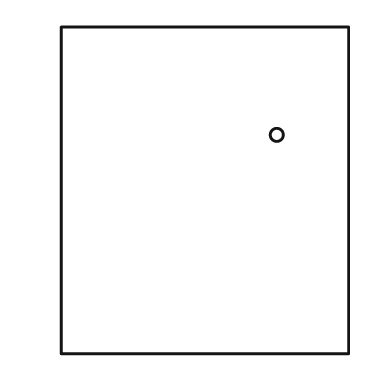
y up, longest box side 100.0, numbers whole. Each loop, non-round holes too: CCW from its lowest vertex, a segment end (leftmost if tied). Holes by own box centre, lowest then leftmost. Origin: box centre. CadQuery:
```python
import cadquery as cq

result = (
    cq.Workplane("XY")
    .moveTo(-44.0, -50.0)
    .lineTo(44.0, -50.0)
    .lineTo(44.0, 50.0)
    .lineTo(-44.0, 50.0)
    .close()
    .moveTo(22.0, 17.0)
    .circle(2.0)
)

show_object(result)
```